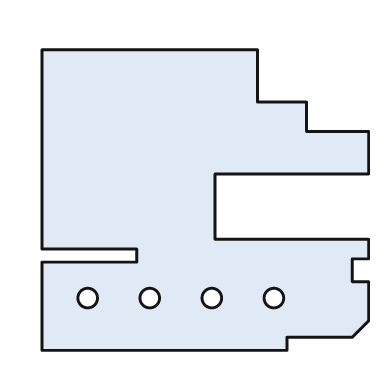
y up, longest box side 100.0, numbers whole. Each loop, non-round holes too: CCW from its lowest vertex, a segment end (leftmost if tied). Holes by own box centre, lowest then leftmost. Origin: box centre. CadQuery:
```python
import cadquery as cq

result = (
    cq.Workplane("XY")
    .moveTo(-50.0, -46.0)
    .lineTo(25.0, -46.0)
    .lineTo(25.0, -42.0)
    .lineTo(45.0, -42.0)
    .lineTo(50.0, -37.0)
    .lineTo(50.0, -25.0)
    .lineTo(45.0, -25.0)
    .lineTo(45.0, -18.0)
    .lineTo(50.0, -18.0)
    .lineTo(50.0, -12.0)
    .lineTo(3.0, -12.0)
    .lineTo(3.0, 8.0)
    .lineTo(50.0, 8.0)
    .lineTo(50.0, 21.0)
    .lineTo(31.0, 21.0)
    .lineTo(31.0, 30.0)
    .lineTo(16.0, 30.0)
    .lineTo(16.0, 46.0)
    .lineTo(-50.0, 46.0)
    .lineTo(-50.0, -15.0)
    .lineTo(-21.0, -15.0)
    .lineTo(-21.0, -19.0)
    .lineTo(-50.0, -19.0)
    .close()
    .moveTo(-36.0, -30.0)
    .circle(3.0)
    .moveTo(-17.0, -30.0)
    .circle(3.0)
    .moveTo(2.0, -30.0)
    .circle(3.0)
    .moveTo(21.0, -30.0)
    .circle(3.0)
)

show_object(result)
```